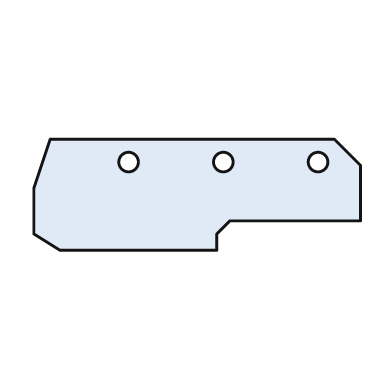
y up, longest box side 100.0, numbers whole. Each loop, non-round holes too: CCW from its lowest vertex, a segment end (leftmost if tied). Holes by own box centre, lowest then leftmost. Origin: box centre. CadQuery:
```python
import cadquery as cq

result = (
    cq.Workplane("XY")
    .moveTo(-42.0, -17.0)
    .lineTo(6.0, -17.0)
    .lineTo(6.0, -12.0)
    .lineTo(10.0, -8.0)
    .lineTo(50.0, -8.0)
    .lineTo(50.0, 9.0)
    .lineTo(42.0, 17.0)
    .lineTo(-45.0, 17.0)
    .lineTo(-50.0, 2.0)
    .lineTo(-50.0, -12.0)
    .close()
    .moveTo(-21.0, 10.0)
    .circle(3.0)
    .moveTo(8.0, 10.0)
    .circle(3.0)
    .moveTo(37.0, 10.0)
    .circle(3.0)
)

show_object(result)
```